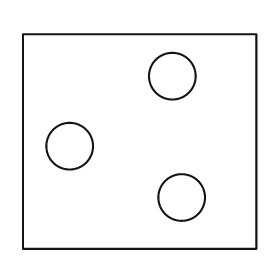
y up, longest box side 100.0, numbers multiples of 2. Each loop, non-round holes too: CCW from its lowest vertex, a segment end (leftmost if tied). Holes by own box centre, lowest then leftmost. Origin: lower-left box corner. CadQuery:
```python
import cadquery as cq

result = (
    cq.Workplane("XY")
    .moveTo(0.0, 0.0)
    .lineTo(100.0, 0.0)
    .lineTo(100.0, 92.0)
    .lineTo(0.0, 92.0)
    .close()
    .moveTo(68.0, 22.0)
    .circle(10.0)
    .moveTo(20.0, 44.0)
    .circle(10.0)
    .moveTo(64.0, 74.0)
    .circle(10.0)
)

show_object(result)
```